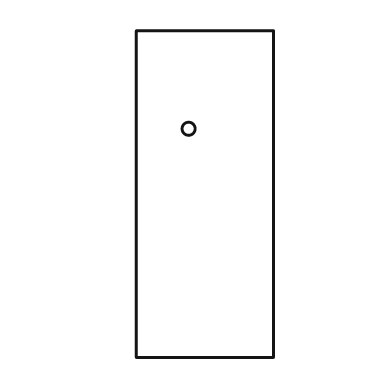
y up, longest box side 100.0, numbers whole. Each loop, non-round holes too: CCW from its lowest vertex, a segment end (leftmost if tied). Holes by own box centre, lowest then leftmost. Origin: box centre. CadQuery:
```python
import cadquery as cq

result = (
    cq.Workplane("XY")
    .moveTo(-21.0, -50.0)
    .lineTo(21.0, -50.0)
    .lineTo(21.0, 50.0)
    .lineTo(-21.0, 50.0)
    .close()
    .moveTo(-5.0, 20.0)
    .circle(2.0)
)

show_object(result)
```